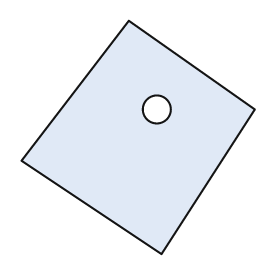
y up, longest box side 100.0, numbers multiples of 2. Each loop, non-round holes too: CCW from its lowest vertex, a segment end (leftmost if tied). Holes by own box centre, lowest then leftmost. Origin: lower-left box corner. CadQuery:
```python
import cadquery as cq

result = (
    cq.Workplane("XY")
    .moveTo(60.0, 0.0)
    .lineTo(100.0, 62.0)
    .lineTo(46.0, 100.0)
    .lineTo(0.0, 40.0)
    .close()
    .moveTo(58.0, 62.0)
    .circle(6.0)
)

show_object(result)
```